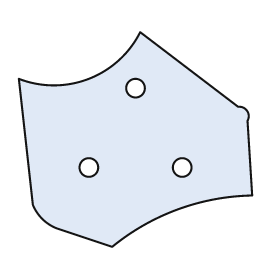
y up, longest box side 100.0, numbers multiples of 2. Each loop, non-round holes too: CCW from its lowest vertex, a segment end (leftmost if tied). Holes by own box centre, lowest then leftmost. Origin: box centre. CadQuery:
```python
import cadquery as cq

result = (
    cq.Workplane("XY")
    .moveTo(-10.0, -46.0)
    .threePointArc((18.0, -30.0), (50.0, -24.0))
    .lineTo(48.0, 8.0)
    .threePointArc((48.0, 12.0), (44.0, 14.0))
    .lineTo(2.0, 46.0)
    .threePointArc((-20.0, 26.0), (-50.0, 26.0))
    .lineTo(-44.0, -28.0)
    .threePointArc((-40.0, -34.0), (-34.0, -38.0))
    .close()
    .moveTo(-20.0, -12.0)
    .circle(4.0)
    .moveTo(20.0, -12.0)
    .circle(4.0)
    .moveTo(0.0, 22.0)
    .circle(4.0)
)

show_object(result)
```